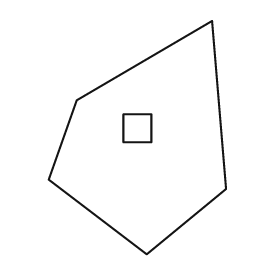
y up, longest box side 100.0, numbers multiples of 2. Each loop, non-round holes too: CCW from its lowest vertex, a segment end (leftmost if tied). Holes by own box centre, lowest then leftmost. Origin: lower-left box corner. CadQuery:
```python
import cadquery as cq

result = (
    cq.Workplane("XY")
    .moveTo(42.0, 0.0)
    .lineTo(76.0, 28.0)
    .lineTo(70.0, 100.0)
    .lineTo(12.0, 66.0)
    .lineTo(0.0, 32.0)
    .close()
    .moveTo(32.0, 48.0)
    .lineTo(44.0, 48.0)
    .lineTo(44.0, 60.0)
    .lineTo(32.0, 60.0)
    .close()
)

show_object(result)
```